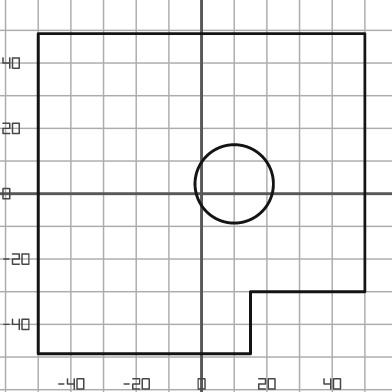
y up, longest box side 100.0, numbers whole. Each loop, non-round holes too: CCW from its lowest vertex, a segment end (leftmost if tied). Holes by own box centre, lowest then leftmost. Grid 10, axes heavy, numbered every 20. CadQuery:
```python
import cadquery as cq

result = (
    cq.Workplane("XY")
    .moveTo(-50.0, -49.0)
    .lineTo(15.0, -49.0)
    .lineTo(15.0, -30.0)
    .lineTo(50.0, -30.0)
    .lineTo(50.0, 49.0)
    .lineTo(-50.0, 49.0)
    .close()
    .moveTo(10.0, 3.0)
    .circle(12.0)
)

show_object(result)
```